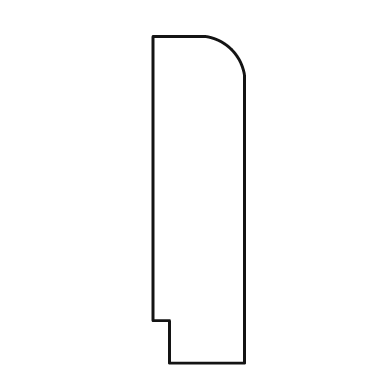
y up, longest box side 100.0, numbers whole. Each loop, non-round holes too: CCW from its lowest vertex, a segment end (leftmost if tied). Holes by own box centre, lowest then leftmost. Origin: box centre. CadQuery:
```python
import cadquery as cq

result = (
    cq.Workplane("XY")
    .moveTo(-9.0, -50.0)
    .lineTo(14.0, -50.0)
    .lineTo(14.0, 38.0)
    .threePointArc((10.0, 46.0), (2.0, 50.0))
    .lineTo(-14.0, 50.0)
    .lineTo(-14.0, -37.0)
    .lineTo(-9.0, -37.0)
    .close()
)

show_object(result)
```